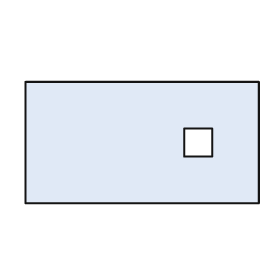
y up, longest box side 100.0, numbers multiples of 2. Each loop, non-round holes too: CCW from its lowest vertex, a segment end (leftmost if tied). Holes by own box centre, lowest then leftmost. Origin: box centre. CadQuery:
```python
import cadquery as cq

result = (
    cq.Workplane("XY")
    .moveTo(-50.0, -26.0)
    .lineTo(50.0, -26.0)
    .lineTo(50.0, 26.0)
    .lineTo(-50.0, 26.0)
    .close()
    .moveTo(18.0, -6.0)
    .lineTo(30.0, -6.0)
    .lineTo(30.0, 6.0)
    .lineTo(18.0, 6.0)
    .close()
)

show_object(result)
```